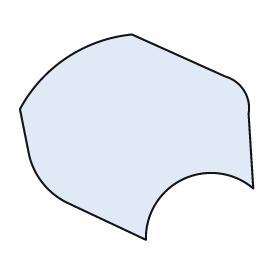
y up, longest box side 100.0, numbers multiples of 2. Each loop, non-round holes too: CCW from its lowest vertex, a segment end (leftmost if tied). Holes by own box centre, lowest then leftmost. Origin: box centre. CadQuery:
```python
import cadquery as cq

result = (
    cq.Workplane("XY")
    .moveTo(4.0, -44.0)
    .threePointArc((20.0, -18.0), (50.0, -22.0))
    .lineTo(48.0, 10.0)
    .threePointArc((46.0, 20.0), (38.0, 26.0))
    .lineTo(-2.0, 44.0)
    .threePointArc((-30.0, 34.0), (-50.0, 12.0))
    .lineTo(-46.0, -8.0)
    .threePointArc((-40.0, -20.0), (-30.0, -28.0))
    .close()
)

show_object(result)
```